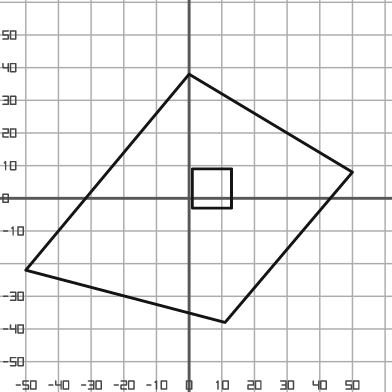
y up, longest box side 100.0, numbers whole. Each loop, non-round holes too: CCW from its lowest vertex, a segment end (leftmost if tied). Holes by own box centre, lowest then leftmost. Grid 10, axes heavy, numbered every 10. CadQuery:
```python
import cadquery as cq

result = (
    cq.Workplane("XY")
    .moveTo(11.0, -38.0)
    .lineTo(50.0, 8.0)
    .lineTo(0.0, 38.0)
    .lineTo(-50.0, -22.0)
    .close()
    .moveTo(1.0, -3.0)
    .lineTo(13.0, -3.0)
    .lineTo(13.0, 9.0)
    .lineTo(1.0, 9.0)
    .close()
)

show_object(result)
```